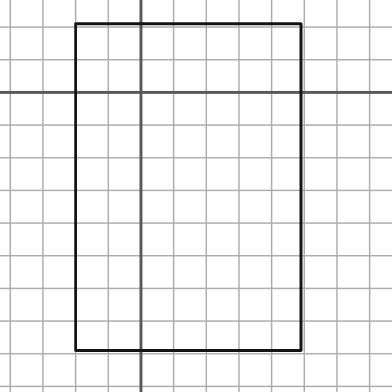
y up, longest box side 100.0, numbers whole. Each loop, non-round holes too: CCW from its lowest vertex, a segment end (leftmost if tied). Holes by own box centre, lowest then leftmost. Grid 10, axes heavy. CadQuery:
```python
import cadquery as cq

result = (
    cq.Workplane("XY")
    .moveTo(-20.0, -79.0)
    .lineTo(49.0, -79.0)
    .lineTo(49.0, 21.0)
    .lineTo(-20.0, 21.0)
    .close()
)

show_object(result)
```